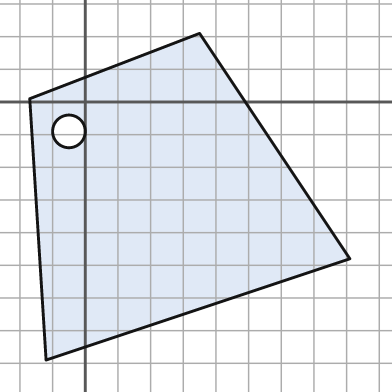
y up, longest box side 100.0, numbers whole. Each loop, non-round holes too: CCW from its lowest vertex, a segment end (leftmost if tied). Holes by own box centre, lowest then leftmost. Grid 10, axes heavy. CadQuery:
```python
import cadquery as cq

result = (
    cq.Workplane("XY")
    .moveTo(-12.0, -79.0)
    .lineTo(81.0, -48.0)
    .lineTo(35.0, 21.0)
    .lineTo(-17.0, 1.0)
    .close()
    .moveTo(-5.0, -9.0)
    .circle(5.0)
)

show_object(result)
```